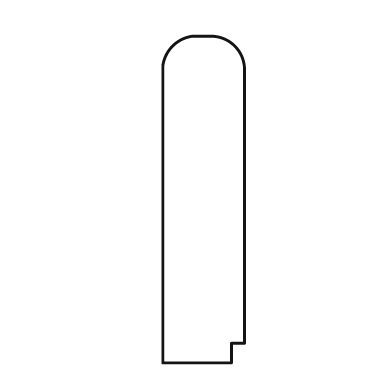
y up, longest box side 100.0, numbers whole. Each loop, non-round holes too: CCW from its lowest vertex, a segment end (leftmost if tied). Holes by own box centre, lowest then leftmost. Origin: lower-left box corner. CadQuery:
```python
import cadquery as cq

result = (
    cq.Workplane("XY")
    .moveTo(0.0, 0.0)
    .lineTo(21.0, 0.0)
    .lineTo(21.0, 6.0)
    .lineTo(25.0, 6.0)
    .lineTo(25.0, 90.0)
    .threePointArc((22.0, 97.0), (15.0, 100.0))
    .lineTo(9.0, 100.0)
    .threePointArc((3.0, 97.0), (0.0, 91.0))
    .close()
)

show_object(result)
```